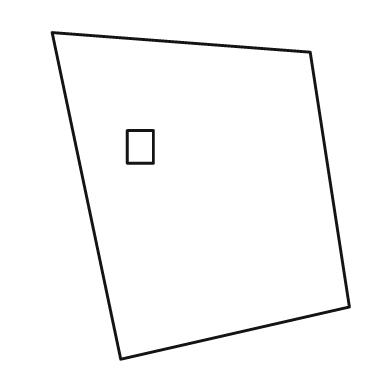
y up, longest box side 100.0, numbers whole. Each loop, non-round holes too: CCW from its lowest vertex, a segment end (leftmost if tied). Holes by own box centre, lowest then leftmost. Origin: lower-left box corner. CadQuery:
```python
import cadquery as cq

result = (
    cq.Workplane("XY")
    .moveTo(21.0, 0.0)
    .lineTo(91.0, 16.0)
    .lineTo(79.0, 94.0)
    .lineTo(0.0, 100.0)
    .close()
    .moveTo(23.0, 60.0)
    .lineTo(31.0, 60.0)
    .lineTo(31.0, 70.0)
    .lineTo(23.0, 70.0)
    .close()
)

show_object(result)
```